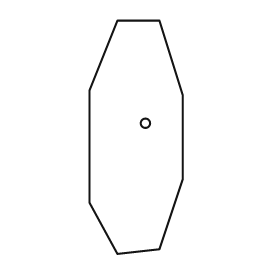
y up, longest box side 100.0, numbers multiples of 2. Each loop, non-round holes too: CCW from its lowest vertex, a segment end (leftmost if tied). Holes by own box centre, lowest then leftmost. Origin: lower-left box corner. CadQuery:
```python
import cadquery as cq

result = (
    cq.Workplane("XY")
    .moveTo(12.0, 0.0)
    .lineTo(30.0, 2.0)
    .lineTo(40.0, 32.0)
    .lineTo(40.0, 68.0)
    .lineTo(30.0, 100.0)
    .lineTo(12.0, 100.0)
    .lineTo(0.0, 70.0)
    .lineTo(0.0, 22.0)
    .close()
    .moveTo(24.0, 56.0)
    .circle(2.0)
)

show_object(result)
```